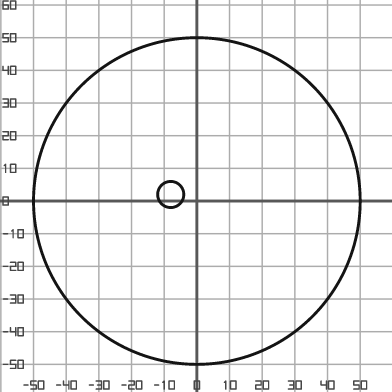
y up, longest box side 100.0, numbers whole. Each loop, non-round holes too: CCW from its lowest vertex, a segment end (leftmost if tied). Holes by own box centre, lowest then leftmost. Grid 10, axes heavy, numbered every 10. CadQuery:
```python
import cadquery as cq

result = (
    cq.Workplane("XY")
    .moveTo(0.0, 0.0)
    .circle(50.0)
    .moveTo(-8.0, 2.0)
    .circle(4.0)
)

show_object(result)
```